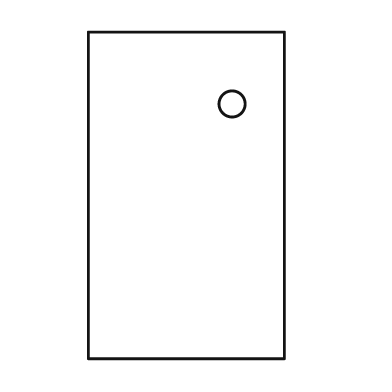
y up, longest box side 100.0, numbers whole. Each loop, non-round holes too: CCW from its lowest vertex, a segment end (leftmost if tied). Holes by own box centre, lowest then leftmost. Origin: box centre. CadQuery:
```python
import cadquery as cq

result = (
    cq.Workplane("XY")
    .moveTo(-30.0, -50.0)
    .lineTo(30.0, -50.0)
    .lineTo(30.0, 50.0)
    .lineTo(-30.0, 50.0)
    .close()
    .moveTo(14.0, 28.0)
    .circle(4.0)
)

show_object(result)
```